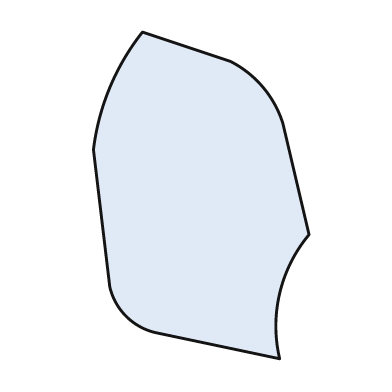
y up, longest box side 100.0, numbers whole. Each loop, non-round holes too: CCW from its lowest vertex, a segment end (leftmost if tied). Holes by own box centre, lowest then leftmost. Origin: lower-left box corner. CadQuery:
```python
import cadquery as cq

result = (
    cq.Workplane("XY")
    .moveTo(57.0, 0.0)
    .threePointArc((57.0, 20.0), (66.0, 38.0))
    .lineTo(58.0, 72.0)
    .threePointArc((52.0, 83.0), (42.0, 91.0))
    .lineTo(15.0, 100.0)
    .threePointArc((5.0, 83.0), (0.0, 64.0))
    .lineTo(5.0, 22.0)
    .threePointArc((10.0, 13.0), (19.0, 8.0))
    .close()
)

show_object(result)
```